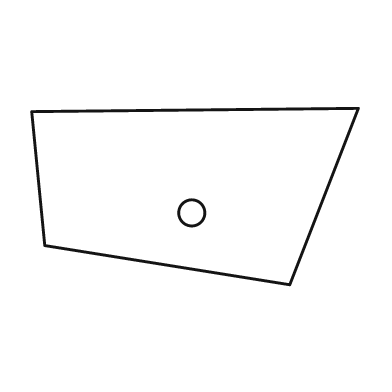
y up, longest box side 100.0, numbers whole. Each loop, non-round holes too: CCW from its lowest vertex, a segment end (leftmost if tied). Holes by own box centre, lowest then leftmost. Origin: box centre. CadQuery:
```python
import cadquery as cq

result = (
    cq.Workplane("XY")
    .moveTo(29.0, -27.0)
    .lineTo(50.0, 27.0)
    .lineTo(-50.0, 26.0)
    .lineTo(-46.0, -15.0)
    .close()
    .moveTo(-1.0, -5.0)
    .circle(4.0)
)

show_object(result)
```